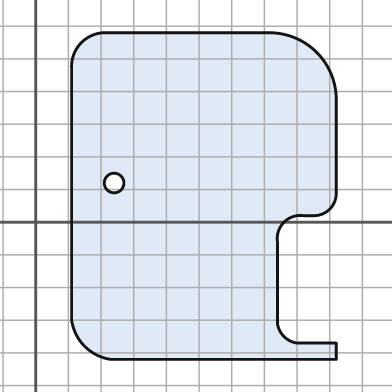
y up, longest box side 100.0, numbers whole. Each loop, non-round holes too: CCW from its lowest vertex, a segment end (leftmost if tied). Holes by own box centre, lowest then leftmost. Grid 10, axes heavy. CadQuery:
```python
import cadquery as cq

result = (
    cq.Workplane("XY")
    .moveTo(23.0, -42.0)
    .lineTo(92.0, -42.0)
    .lineTo(92.0, -37.0)
    .lineTo(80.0, -37.0)
    .threePointArc((76.0, -35.0), (74.0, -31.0))
    .lineTo(74.0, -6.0)
    .threePointArc((76.0, 0.0), (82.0, 2.0))
    .lineTo(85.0, 2.0)
    .threePointArc((90.0, 4.0), (92.0, 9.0))
    .lineTo(92.0, 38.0)
    .threePointArc((86.0, 52.0), (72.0, 58.0))
    .lineTo(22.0, 58.0)
    .threePointArc((14.0, 55.0), (11.0, 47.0))
    .lineTo(11.0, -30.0)
    .threePointArc((15.0, -38.0), (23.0, -42.0))
    .close()
    .moveTo(24.0, 12.0)
    .circle(3.0)
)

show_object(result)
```